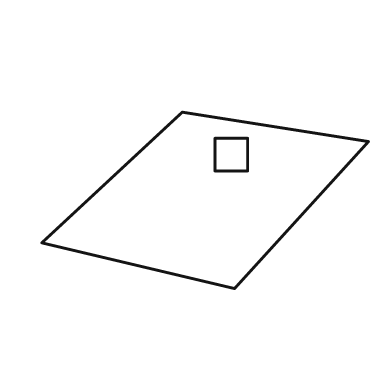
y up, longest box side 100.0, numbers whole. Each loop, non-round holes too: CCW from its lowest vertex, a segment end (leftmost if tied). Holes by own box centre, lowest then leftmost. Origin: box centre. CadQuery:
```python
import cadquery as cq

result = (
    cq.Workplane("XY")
    .moveTo(9.0, -27.0)
    .lineTo(50.0, 18.0)
    .lineTo(-7.0, 27.0)
    .lineTo(-50.0, -13.0)
    .close()
    .moveTo(3.0, 9.0)
    .lineTo(13.0, 9.0)
    .lineTo(13.0, 19.0)
    .lineTo(3.0, 19.0)
    .close()
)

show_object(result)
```